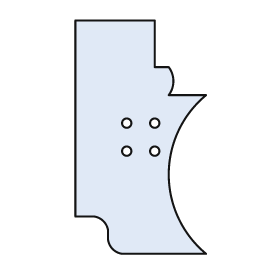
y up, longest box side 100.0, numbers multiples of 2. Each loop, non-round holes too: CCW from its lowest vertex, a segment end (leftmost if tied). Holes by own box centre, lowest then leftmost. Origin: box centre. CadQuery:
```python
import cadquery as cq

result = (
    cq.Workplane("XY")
    .moveTo(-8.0, -50.0)
    .lineTo(28.0, -50.0)
    .threePointArc((12.0, -16.0), (28.0, 18.0))
    .lineTo(12.0, 18.0)
    .threePointArc((14.0, 24.0), (12.0, 30.0))
    .lineTo(6.0, 30.0)
    .lineTo(6.0, 50.0)
    .lineTo(-28.0, 50.0)
    .lineTo(-28.0, -34.0)
    .lineTo(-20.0, -34.0)
    .threePointArc((-16.0, -36.0), (-14.0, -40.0))
    .lineTo(-14.0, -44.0)
    .threePointArc((-12.0, -48.0), (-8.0, -50.0))
    .close()
    .moveTo(-6.0, -6.0)
    .circle(2.0)
    .moveTo(6.0, -6.0)
    .circle(2.0)
    .moveTo(-6.0, 6.0)
    .circle(2.0)
    .moveTo(6.0, 6.0)
    .circle(2.0)
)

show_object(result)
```